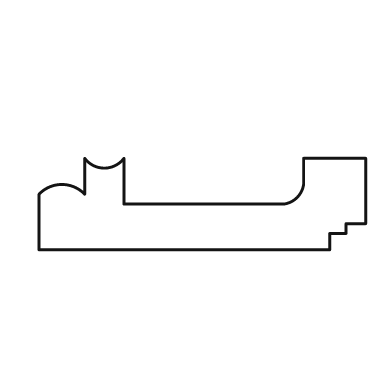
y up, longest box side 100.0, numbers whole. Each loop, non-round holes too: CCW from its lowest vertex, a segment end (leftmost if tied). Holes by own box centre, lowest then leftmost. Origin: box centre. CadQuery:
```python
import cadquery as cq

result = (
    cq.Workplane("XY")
    .moveTo(-50.0, -14.0)
    .lineTo(39.0, -14.0)
    .lineTo(39.0, -9.0)
    .lineTo(44.0, -9.0)
    .lineTo(44.0, -6.0)
    .lineTo(50.0, -6.0)
    .lineTo(50.0, 14.0)
    .lineTo(31.0, 14.0)
    .lineTo(31.0, 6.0)
    .threePointArc((29.0, 2.0), (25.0, 0.0))
    .lineTo(-24.0, 0.0)
    .lineTo(-24.0, 14.0)
    .threePointArc((-30.0, 11.0), (-36.0, 14.0))
    .lineTo(-36.0, 3.0)
    .threePointArc((-43.0, 6.0), (-50.0, 3.0))
    .close()
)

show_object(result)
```